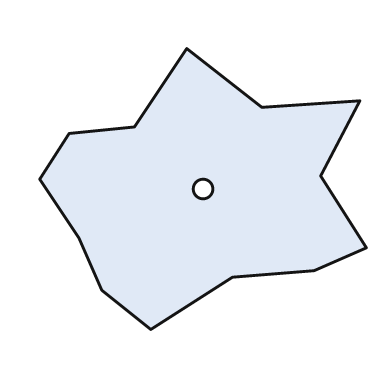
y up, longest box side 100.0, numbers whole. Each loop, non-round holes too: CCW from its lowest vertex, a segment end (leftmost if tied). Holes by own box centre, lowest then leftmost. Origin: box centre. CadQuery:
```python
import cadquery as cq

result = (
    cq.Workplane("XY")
    .moveTo(-16.0, -43.0)
    .lineTo(9.0, -27.0)
    .lineTo(34.0, -25.0)
    .lineTo(50.0, -18.0)
    .lineTo(36.0, 4.0)
    .lineTo(48.0, 27.0)
    .lineTo(18.0, 25.0)
    .lineTo(-5.0, 43.0)
    .lineTo(-21.0, 19.0)
    .lineTo(-41.0, 17.0)
    .lineTo(-50.0, 3.0)
    .lineTo(-38.0, -15.0)
    .lineTo(-31.0, -31.0)
    .close()
    .moveTo(0.0, 0.0)
    .circle(3.0)
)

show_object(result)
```